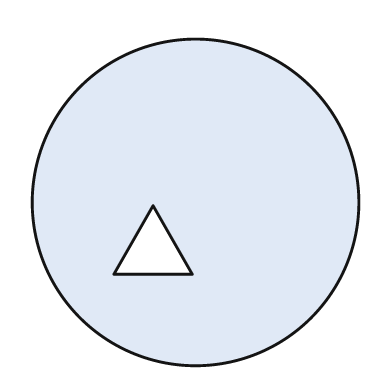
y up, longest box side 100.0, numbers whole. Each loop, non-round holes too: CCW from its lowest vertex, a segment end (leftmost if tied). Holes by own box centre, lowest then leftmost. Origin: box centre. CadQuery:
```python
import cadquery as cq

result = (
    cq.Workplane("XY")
    .moveTo(0.0, 0.0)
    .circle(50.0)
    .moveTo(-25.0, -22.0)
    .lineTo(-1.0, -22.0)
    .lineTo(-13.0, -1.0)
    .close()
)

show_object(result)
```